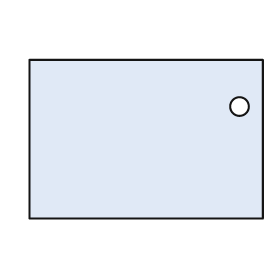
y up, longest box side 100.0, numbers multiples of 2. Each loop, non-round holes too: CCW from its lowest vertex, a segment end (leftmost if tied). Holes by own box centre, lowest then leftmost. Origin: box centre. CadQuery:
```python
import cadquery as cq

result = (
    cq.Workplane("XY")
    .moveTo(-50.0, -34.0)
    .lineTo(50.0, -34.0)
    .lineTo(50.0, 34.0)
    .lineTo(-50.0, 34.0)
    .close()
    .moveTo(40.0, 14.0)
    .circle(4.0)
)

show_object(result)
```